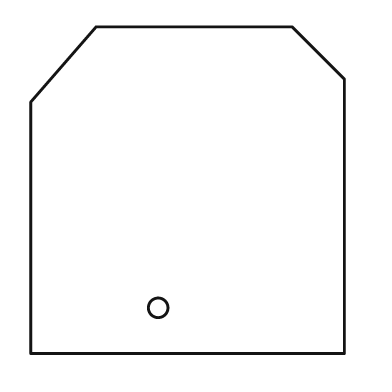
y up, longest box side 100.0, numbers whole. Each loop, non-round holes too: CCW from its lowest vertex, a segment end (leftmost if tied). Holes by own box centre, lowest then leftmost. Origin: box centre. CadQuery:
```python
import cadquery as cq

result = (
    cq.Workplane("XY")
    .moveTo(-48.0, -50.0)
    .lineTo(48.0, -50.0)
    .lineTo(48.0, 34.0)
    .lineTo(32.0, 50.0)
    .lineTo(-28.0, 50.0)
    .lineTo(-48.0, 27.0)
    .close()
    .moveTo(-9.0, -36.0)
    .circle(3.0)
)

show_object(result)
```